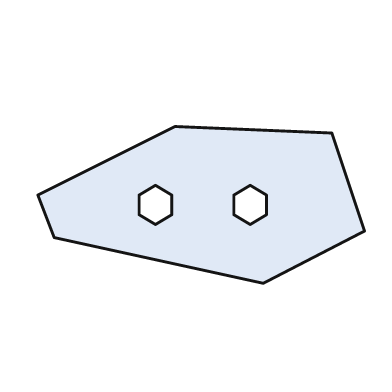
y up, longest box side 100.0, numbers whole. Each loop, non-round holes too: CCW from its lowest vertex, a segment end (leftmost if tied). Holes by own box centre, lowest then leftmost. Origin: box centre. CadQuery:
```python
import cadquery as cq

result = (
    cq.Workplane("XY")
    .moveTo(19.0, -24.0)
    .lineTo(50.0, -8.0)
    .lineTo(40.0, 22.0)
    .lineTo(-8.0, 24.0)
    .lineTo(-50.0, 3.0)
    .lineTo(-45.0, -10.0)
    .close()
    .moveTo(-14.0, -6.0)
    .lineTo(-9.0, -3.0)
    .lineTo(-9.0, 3.0)
    .lineTo(-14.0, 6.0)
    .lineTo(-19.0, 3.0)
    .lineTo(-19.0, -3.0)
    .close()
    .moveTo(15.0, -6.0)
    .lineTo(20.0, -3.0)
    .lineTo(20.0, 3.0)
    .lineTo(15.0, 6.0)
    .lineTo(10.0, 3.0)
    .lineTo(10.0, -3.0)
    .close()
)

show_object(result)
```